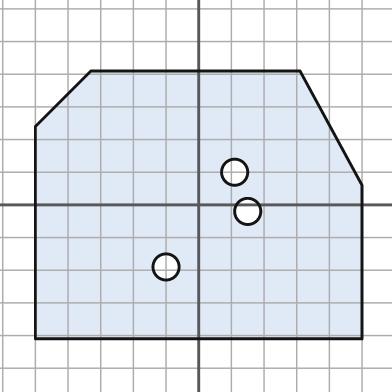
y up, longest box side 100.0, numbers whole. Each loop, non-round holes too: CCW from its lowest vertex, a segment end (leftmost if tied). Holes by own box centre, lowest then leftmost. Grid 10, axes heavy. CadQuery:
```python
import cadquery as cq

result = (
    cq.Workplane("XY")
    .moveTo(-50.0, -41.0)
    .lineTo(50.0, -41.0)
    .lineTo(50.0, 6.0)
    .lineTo(31.0, 41.0)
    .lineTo(-33.0, 41.0)
    .lineTo(-50.0, 24.0)
    .close()
    .moveTo(-10.0, -19.0)
    .circle(4.0)
    .moveTo(15.0, -2.0)
    .circle(4.0)
    .moveTo(11.0, 10.0)
    .circle(4.0)
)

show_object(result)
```